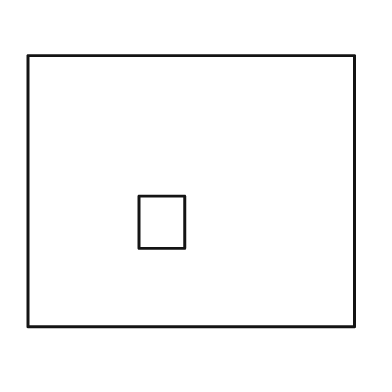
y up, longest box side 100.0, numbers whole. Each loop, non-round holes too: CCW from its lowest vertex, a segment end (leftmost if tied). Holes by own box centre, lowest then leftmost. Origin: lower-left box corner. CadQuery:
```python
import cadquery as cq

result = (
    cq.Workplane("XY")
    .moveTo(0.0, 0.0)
    .lineTo(100.0, 0.0)
    .lineTo(100.0, 83.0)
    .lineTo(0.0, 83.0)
    .close()
    .moveTo(34.0, 24.0)
    .lineTo(48.0, 24.0)
    .lineTo(48.0, 40.0)
    .lineTo(34.0, 40.0)
    .close()
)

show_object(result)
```